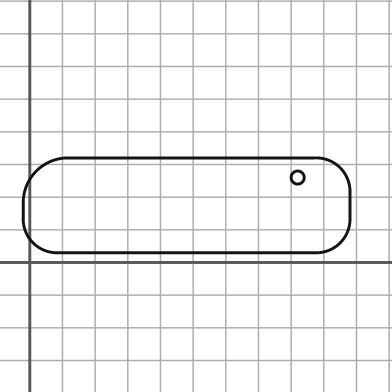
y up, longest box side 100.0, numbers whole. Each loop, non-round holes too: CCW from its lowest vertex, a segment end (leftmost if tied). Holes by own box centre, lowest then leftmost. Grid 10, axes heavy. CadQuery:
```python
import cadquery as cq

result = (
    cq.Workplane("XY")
    .moveTo(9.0, 3.0)
    .lineTo(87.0, 3.0)
    .threePointArc((95.0, 6.0), (98.0, 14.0))
    .lineTo(98.0, 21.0)
    .threePointArc((95.0, 29.0), (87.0, 32.0))
    .lineTo(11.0, 32.0)
    .threePointArc((2.0, 28.0), (-2.0, 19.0))
    .lineTo(-2.0, 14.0)
    .threePointArc((1.0, 6.0), (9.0, 3.0))
    .close()
    .moveTo(82.0, 26.0)
    .circle(2.0)
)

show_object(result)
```